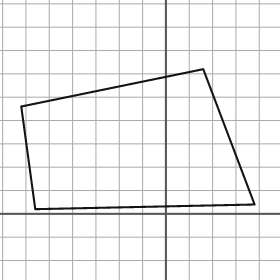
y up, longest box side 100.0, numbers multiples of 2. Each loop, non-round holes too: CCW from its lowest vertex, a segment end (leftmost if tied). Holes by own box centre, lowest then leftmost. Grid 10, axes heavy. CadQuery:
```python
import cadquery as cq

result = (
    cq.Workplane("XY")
    .moveTo(-56.0, 2.0)
    .lineTo(38.0, 4.0)
    .lineTo(16.0, 62.0)
    .lineTo(-62.0, 46.0)
    .close()
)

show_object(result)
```